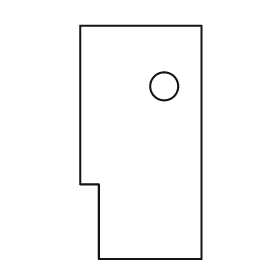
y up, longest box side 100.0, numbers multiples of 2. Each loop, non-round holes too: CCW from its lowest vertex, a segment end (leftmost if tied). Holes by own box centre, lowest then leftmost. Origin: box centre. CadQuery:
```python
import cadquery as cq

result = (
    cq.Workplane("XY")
    .moveTo(-18.0, -50.0)
    .lineTo(26.0, -50.0)
    .lineTo(26.0, 50.0)
    .lineTo(-26.0, 50.0)
    .lineTo(-26.0, -18.0)
    .lineTo(-18.0, -18.0)
    .close()
    .moveTo(10.0, 24.0)
    .circle(6.0)
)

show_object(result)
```